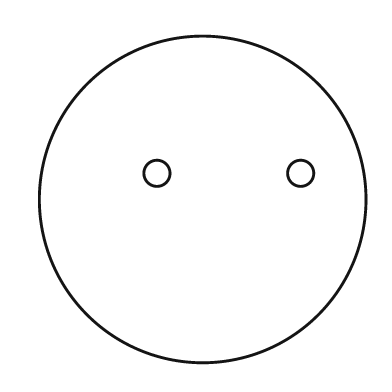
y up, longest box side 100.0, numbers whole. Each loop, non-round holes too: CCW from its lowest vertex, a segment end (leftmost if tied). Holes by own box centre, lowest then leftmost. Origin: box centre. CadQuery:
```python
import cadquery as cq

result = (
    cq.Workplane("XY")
    .moveTo(0.0, 0.0)
    .circle(50.0)
    .moveTo(-14.0, 8.0)
    .circle(4.0)
    .moveTo(30.0, 8.0)
    .circle(4.0)
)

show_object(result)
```